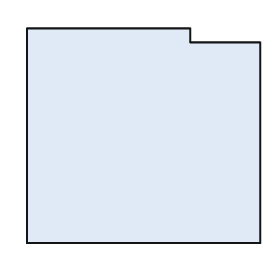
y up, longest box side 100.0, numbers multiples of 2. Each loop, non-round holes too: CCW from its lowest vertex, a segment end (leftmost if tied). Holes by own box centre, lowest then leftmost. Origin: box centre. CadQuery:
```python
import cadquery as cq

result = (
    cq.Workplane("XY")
    .moveTo(-50.0, -46.0)
    .lineTo(50.0, -46.0)
    .lineTo(50.0, 40.0)
    .lineTo(20.0, 40.0)
    .lineTo(20.0, 46.0)
    .lineTo(-50.0, 46.0)
    .close()
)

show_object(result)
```